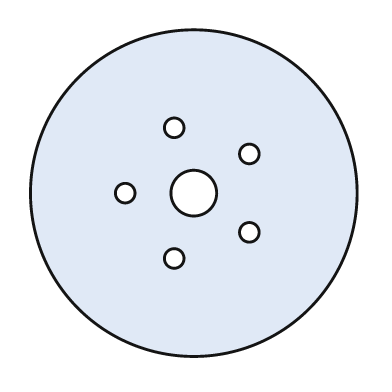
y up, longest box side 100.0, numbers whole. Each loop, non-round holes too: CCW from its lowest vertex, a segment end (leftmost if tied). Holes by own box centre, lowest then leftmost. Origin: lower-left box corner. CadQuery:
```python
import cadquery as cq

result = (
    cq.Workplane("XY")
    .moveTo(50.0, 50.0)
    .circle(50.0)
    .moveTo(44.0, 30.0)
    .circle(3.0)
    .moveTo(67.0, 38.0)
    .circle(3.0)
    .moveTo(29.0, 50.0)
    .circle(3.0)
    .moveTo(50.0, 50.0)
    .circle(7.0)
    .moveTo(67.0, 62.0)
    .circle(3.0)
    .moveTo(44.0, 70.0)
    .circle(3.0)
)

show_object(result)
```